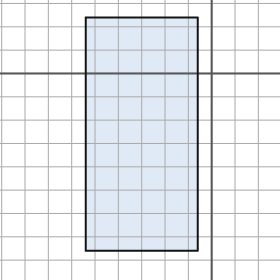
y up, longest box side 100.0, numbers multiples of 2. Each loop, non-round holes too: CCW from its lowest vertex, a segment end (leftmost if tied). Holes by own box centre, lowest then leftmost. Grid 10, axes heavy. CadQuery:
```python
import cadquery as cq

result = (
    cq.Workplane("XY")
    .moveTo(-54.0, -76.0)
    .lineTo(-6.0, -76.0)
    .lineTo(-6.0, 24.0)
    .lineTo(-54.0, 24.0)
    .close()
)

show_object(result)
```